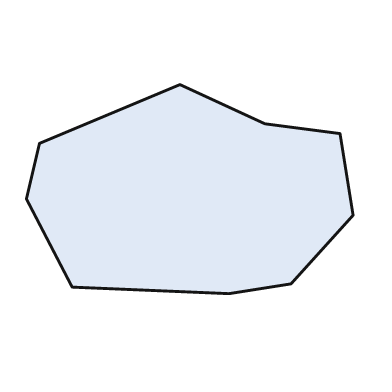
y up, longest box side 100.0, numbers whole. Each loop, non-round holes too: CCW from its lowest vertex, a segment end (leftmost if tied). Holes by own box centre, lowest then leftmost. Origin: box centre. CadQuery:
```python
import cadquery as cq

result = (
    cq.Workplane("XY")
    .moveTo(12.0, -32.0)
    .lineTo(31.0, -29.0)
    .lineTo(50.0, -8.0)
    .lineTo(46.0, 17.0)
    .lineTo(23.0, 20.0)
    .lineTo(-3.0, 32.0)
    .lineTo(-46.0, 14.0)
    .lineTo(-50.0, -3.0)
    .lineTo(-36.0, -30.0)
    .close()
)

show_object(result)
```